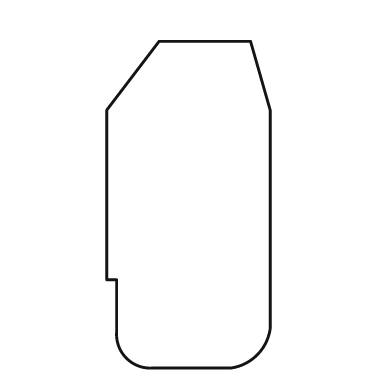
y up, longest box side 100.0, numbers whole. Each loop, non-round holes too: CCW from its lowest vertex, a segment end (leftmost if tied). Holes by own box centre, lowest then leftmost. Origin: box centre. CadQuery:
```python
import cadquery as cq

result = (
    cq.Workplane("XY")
    .moveTo(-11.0, -50.0)
    .lineTo(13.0, -50.0)
    .threePointArc((21.0, -46.0), (25.0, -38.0))
    .lineTo(25.0, 29.0)
    .lineTo(19.0, 50.0)
    .lineTo(-9.0, 50.0)
    .lineTo(-25.0, 29.0)
    .lineTo(-25.0, -23.0)
    .lineTo(-22.0, -23.0)
    .lineTo(-22.0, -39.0)
    .threePointArc((-19.0, -47.0), (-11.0, -50.0))
    .close()
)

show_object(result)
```